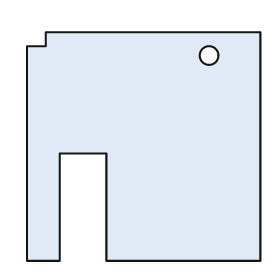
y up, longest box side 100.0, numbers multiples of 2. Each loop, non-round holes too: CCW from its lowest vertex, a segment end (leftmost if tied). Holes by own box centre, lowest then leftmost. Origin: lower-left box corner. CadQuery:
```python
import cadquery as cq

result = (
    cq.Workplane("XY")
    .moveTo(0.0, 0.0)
    .lineTo(14.0, 0.0)
    .lineTo(14.0, 46.0)
    .lineTo(34.0, 46.0)
    .lineTo(34.0, 0.0)
    .lineTo(100.0, 0.0)
    .lineTo(100.0, 98.0)
    .lineTo(8.0, 98.0)
    .lineTo(8.0, 92.0)
    .lineTo(0.0, 92.0)
    .close()
    .moveTo(78.0, 88.0)
    .circle(4.0)
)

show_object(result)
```